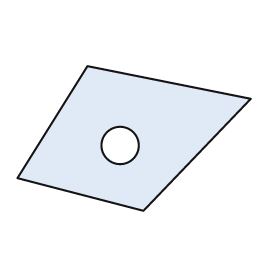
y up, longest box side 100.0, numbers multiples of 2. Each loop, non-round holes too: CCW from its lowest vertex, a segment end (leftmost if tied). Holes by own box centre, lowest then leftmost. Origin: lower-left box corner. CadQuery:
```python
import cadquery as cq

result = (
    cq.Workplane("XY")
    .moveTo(54.0, 0.0)
    .lineTo(100.0, 48.0)
    .lineTo(30.0, 62.0)
    .lineTo(0.0, 14.0)
    .close()
    .moveTo(44.0, 28.0)
    .circle(8.0)
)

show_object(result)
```